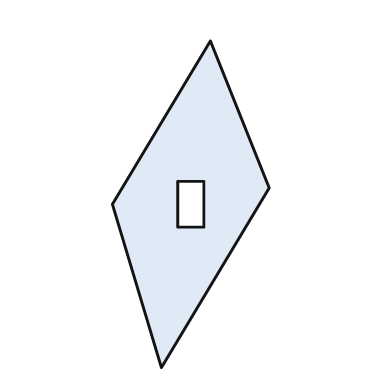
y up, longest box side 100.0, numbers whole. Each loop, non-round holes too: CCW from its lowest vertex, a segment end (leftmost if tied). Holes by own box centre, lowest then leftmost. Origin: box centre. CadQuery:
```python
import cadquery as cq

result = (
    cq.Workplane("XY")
    .moveTo(-9.0, -50.0)
    .lineTo(24.0, 5.0)
    .lineTo(6.0, 50.0)
    .lineTo(-24.0, 0.0)
    .close()
    .moveTo(-4.0, -7.0)
    .lineTo(4.0, -7.0)
    .lineTo(4.0, 7.0)
    .lineTo(-4.0, 7.0)
    .close()
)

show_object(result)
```